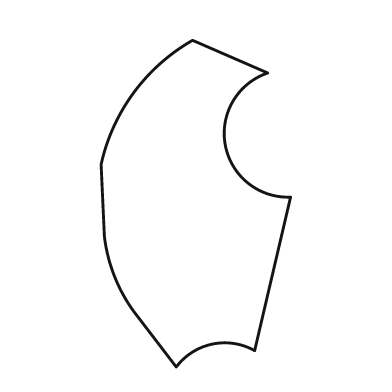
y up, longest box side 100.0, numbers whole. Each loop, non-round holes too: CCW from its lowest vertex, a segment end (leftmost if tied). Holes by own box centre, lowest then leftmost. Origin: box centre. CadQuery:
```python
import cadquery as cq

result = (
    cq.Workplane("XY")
    .moveTo(-6.0, -50.0)
    .threePointArc((5.0, -43.0), (18.0, -45.0))
    .lineTo(29.0, 2.0)
    .threePointArc((9.0, 18.0), (22.0, 40.0))
    .lineTo(-1.0, 50.0)
    .threePointArc((-19.0, 34.0), (-29.0, 12.0))
    .lineTo(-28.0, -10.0)
    .threePointArc((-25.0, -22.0), (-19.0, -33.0))
    .close()
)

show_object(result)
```